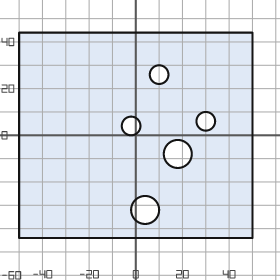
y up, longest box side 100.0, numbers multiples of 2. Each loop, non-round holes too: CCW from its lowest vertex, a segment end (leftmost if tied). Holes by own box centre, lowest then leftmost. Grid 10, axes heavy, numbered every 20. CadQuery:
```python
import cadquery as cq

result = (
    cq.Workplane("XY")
    .moveTo(-50.0, -44.0)
    .lineTo(50.0, -44.0)
    .lineTo(50.0, 44.0)
    .lineTo(-50.0, 44.0)
    .close()
    .moveTo(4.0, -32.0)
    .circle(6.0)
    .moveTo(18.0, -8.0)
    .circle(6.0)
    .moveTo(-2.0, 4.0)
    .circle(4.0)
    .moveTo(30.0, 6.0)
    .circle(4.0)
    .moveTo(10.0, 26.0)
    .circle(4.0)
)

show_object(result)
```